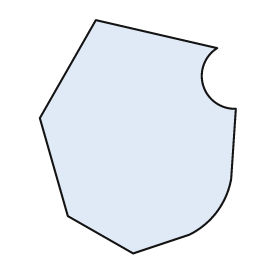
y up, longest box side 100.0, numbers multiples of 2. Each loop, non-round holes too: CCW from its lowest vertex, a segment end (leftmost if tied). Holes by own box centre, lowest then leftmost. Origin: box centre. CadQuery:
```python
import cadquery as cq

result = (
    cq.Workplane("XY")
    .moveTo(-2.0, -50.0)
    .lineTo(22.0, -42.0)
    .threePointArc((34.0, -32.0), (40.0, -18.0))
    .lineTo(42.0, 12.0)
    .threePointArc((28.0, 22.0), (34.0, 38.0))
    .lineTo(-18.0, 50.0)
    .lineTo(-42.0, 8.0)
    .lineTo(-30.0, -34.0)
    .close()
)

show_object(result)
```